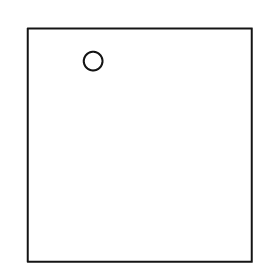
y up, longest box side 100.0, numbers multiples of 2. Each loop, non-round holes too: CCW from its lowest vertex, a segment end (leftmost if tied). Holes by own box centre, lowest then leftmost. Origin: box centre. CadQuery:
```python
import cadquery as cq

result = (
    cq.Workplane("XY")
    .moveTo(-48.0, -50.0)
    .lineTo(48.0, -50.0)
    .lineTo(48.0, 50.0)
    .lineTo(-48.0, 50.0)
    .close()
    .moveTo(-20.0, 36.0)
    .circle(4.0)
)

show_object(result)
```